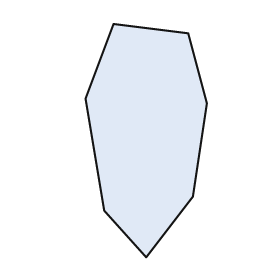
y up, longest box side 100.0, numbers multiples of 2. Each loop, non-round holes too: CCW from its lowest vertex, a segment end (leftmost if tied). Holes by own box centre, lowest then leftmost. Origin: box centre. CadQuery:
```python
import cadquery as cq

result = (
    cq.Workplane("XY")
    .moveTo(0.0, -50.0)
    .lineTo(20.0, -24.0)
    .lineTo(26.0, 16.0)
    .lineTo(18.0, 46.0)
    .lineTo(-14.0, 50.0)
    .lineTo(-26.0, 18.0)
    .lineTo(-18.0, -30.0)
    .close()
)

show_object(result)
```